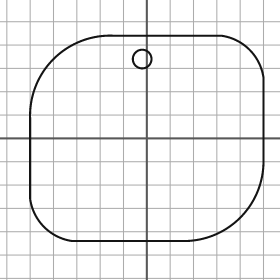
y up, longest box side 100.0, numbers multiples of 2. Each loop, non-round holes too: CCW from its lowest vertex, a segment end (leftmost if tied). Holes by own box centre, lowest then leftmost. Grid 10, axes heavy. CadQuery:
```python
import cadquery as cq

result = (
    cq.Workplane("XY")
    .moveTo(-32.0, -44.0)
    .lineTo(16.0, -44.0)
    .threePointArc((40.0, -34.0), (50.0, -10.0))
    .lineTo(50.0, 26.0)
    .threePointArc((44.0, 38.0), (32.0, 44.0))
    .lineTo(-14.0, 44.0)
    .threePointArc((-40.0, 34.0), (-50.0, 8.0))
    .lineTo(-50.0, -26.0)
    .threePointArc((-44.0, -38.0), (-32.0, -44.0))
    .close()
    .moveTo(-2.0, 34.0)
    .circle(4.0)
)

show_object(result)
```